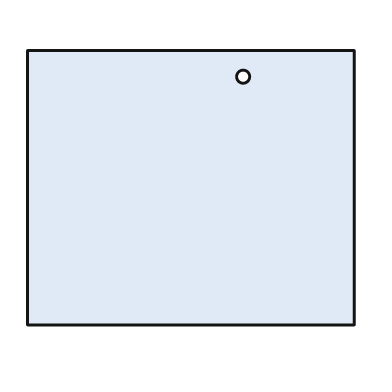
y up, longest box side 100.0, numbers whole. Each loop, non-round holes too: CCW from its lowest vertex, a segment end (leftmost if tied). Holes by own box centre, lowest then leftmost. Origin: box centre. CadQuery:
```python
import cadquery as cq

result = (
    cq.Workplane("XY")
    .moveTo(-50.0, -42.0)
    .lineTo(50.0, -42.0)
    .lineTo(50.0, 42.0)
    .lineTo(-50.0, 42.0)
    .close()
    .moveTo(16.0, 34.0)
    .circle(2.0)
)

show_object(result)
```